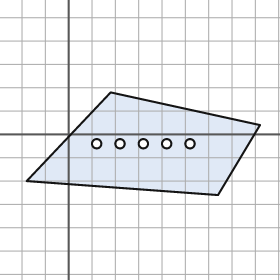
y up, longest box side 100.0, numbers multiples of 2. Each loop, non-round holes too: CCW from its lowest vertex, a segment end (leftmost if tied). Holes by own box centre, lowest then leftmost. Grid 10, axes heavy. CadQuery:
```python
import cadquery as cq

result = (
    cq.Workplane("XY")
    .moveTo(64.0, -26.0)
    .lineTo(82.0, 4.0)
    .lineTo(18.0, 18.0)
    .lineTo(-18.0, -20.0)
    .close()
    .moveTo(12.0, -4.0)
    .circle(2.0)
    .moveTo(22.0, -4.0)
    .circle(2.0)
    .moveTo(32.0, -4.0)
    .circle(2.0)
    .moveTo(42.0, -4.0)
    .circle(2.0)
    .moveTo(52.0, -4.0)
    .circle(2.0)
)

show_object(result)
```